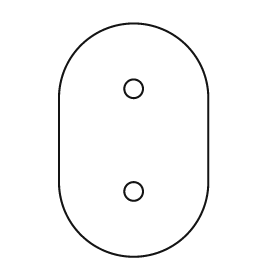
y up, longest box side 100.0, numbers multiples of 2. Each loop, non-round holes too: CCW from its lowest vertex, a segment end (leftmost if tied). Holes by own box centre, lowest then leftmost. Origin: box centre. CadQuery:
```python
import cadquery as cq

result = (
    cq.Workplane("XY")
    .moveTo(-32.0, -18.0)
    .threePointArc((0.0, -50.0), (32.0, -18.0))
    .lineTo(32.0, 18.0)
    .threePointArc((0.0, 50.0), (-32.0, 18.0))
    .close()
    .moveTo(0.0, -22.0)
    .circle(4.0)
    .moveTo(0.0, 22.0)
    .circle(4.0)
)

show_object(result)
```